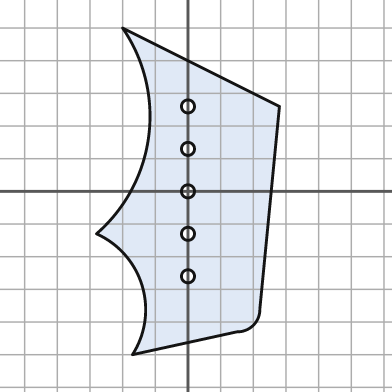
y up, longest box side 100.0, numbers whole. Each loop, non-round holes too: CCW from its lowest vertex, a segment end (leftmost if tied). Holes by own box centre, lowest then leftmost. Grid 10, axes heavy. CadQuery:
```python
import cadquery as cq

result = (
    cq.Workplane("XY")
    .moveTo(-17.0, -50.0)
    .lineTo(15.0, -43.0)
    .threePointArc((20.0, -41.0), (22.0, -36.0))
    .lineTo(28.0, 26.0)
    .lineTo(-20.0, 50.0)
    .threePointArc((-12.0, 17.0), (-28.0, -13.0))
    .threePointArc((-14.0, -29.0), (-17.0, -50.0))
    .close()
    .moveTo(0.0, -26.0)
    .circle(2.0)
    .moveTo(0.0, -13.0)
    .circle(2.0)
    .moveTo(0.0, 0.0)
    .circle(2.0)
    .moveTo(0.0, 13.0)
    .circle(2.0)
    .moveTo(0.0, 26.0)
    .circle(2.0)
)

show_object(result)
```